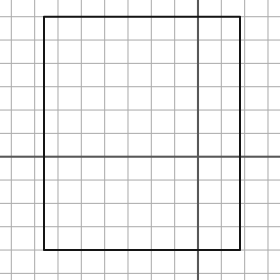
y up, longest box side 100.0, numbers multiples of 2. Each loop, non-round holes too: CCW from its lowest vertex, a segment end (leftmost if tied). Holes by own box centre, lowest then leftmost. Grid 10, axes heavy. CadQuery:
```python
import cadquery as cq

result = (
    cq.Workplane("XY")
    .moveTo(-66.0, -40.0)
    .lineTo(18.0, -40.0)
    .lineTo(18.0, 60.0)
    .lineTo(-66.0, 60.0)
    .close()
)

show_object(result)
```